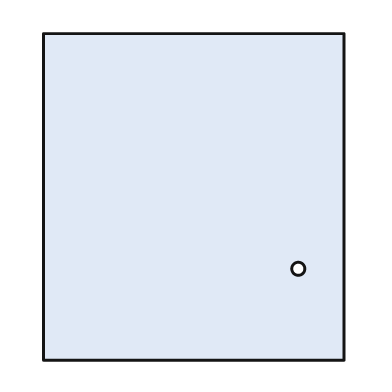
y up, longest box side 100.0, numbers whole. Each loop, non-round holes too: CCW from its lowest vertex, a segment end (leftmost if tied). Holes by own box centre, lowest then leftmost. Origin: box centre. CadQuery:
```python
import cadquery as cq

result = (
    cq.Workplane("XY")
    .moveTo(-46.0, -50.0)
    .lineTo(46.0, -50.0)
    .lineTo(46.0, 50.0)
    .lineTo(-46.0, 50.0)
    .close()
    .moveTo(32.0, -22.0)
    .circle(2.0)
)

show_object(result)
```